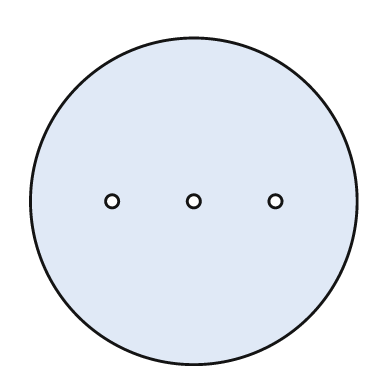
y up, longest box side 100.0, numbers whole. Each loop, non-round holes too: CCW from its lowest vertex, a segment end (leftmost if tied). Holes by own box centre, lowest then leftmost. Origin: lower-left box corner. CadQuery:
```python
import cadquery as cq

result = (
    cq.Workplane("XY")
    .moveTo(50.0, 50.0)
    .circle(50.0)
    .moveTo(25.0, 50.0)
    .circle(2.0)
    .moveTo(50.0, 50.0)
    .circle(2.0)
    .moveTo(75.0, 50.0)
    .circle(2.0)
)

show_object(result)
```